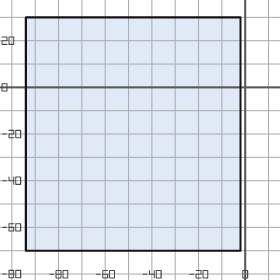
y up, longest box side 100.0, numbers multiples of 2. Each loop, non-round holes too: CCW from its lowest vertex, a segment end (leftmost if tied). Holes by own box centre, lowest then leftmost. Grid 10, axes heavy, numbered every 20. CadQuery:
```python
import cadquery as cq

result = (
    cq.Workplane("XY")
    .moveTo(-94.0, -70.0)
    .lineTo(-2.0, -70.0)
    .lineTo(-2.0, 30.0)
    .lineTo(-94.0, 30.0)
    .close()
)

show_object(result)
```